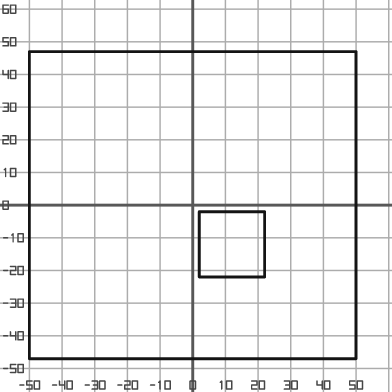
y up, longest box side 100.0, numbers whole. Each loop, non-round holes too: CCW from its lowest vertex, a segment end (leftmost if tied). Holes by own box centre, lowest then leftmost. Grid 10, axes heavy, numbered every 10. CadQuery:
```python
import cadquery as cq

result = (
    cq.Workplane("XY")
    .moveTo(-50.0, -47.0)
    .lineTo(50.0, -47.0)
    .lineTo(50.0, 47.0)
    .lineTo(-50.0, 47.0)
    .close()
    .moveTo(2.0, -22.0)
    .lineTo(22.0, -22.0)
    .lineTo(22.0, -2.0)
    .lineTo(2.0, -2.0)
    .close()
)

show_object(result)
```